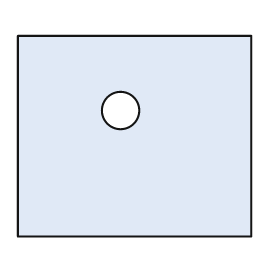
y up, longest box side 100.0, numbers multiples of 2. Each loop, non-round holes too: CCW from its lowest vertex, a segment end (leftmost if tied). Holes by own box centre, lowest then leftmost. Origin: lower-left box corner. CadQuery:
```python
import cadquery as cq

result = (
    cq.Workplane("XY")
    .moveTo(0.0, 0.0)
    .lineTo(100.0, 0.0)
    .lineTo(100.0, 86.0)
    .lineTo(0.0, 86.0)
    .close()
    .moveTo(44.0, 54.0)
    .circle(8.0)
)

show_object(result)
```